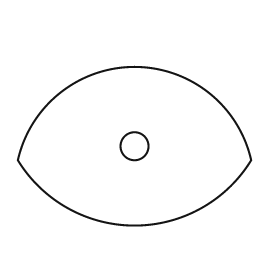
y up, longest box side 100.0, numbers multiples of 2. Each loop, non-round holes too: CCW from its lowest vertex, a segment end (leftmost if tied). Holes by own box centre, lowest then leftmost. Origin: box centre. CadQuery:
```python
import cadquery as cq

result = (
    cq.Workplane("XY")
    .moveTo(-50.0, -6.0)
    .threePointArc((0.0, -34.0), (50.0, -6.0))
    .threePointArc((0.0, 34.0), (-50.0, -6.0))
    .close()
    .moveTo(0.0, 0.0)
    .circle(6.0)
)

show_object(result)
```